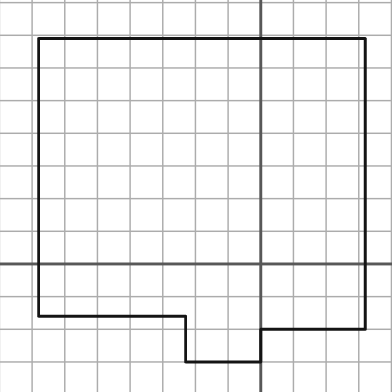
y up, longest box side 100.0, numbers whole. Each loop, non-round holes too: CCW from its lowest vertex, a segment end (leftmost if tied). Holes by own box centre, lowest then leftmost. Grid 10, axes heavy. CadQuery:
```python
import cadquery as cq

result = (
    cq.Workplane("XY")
    .moveTo(-23.0, -30.0)
    .lineTo(0.0, -30.0)
    .lineTo(0.0, -20.0)
    .lineTo(32.0, -20.0)
    .lineTo(32.0, 69.0)
    .lineTo(-68.0, 69.0)
    .lineTo(-68.0, -16.0)
    .lineTo(-23.0, -16.0)
    .close()
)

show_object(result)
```